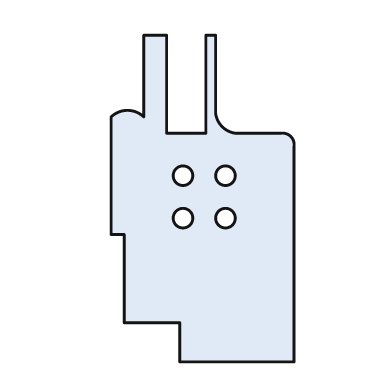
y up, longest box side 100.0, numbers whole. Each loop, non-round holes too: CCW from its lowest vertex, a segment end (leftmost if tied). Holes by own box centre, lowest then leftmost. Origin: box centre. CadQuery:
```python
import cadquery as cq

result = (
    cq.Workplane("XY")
    .moveTo(-7.0, -50.0)
    .lineTo(28.0, -50.0)
    .lineTo(28.0, 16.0)
    .threePointArc((27.0, 19.0), (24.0, 20.0))
    .lineTo(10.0, 20.0)
    .threePointArc((6.0, 22.0), (4.0, 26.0))
    .lineTo(4.0, 50.0)
    .lineTo(1.0, 50.0)
    .lineTo(1.0, 20.0)
    .lineTo(-11.0, 20.0)
    .lineTo(-11.0, 50.0)
    .lineTo(-18.0, 50.0)
    .lineTo(-18.0, 25.0)
    .threePointArc((-23.0, 27.0), (-28.0, 25.0))
    .lineTo(-28.0, -11.0)
    .lineTo(-24.0, -11.0)
    .lineTo(-24.0, -38.0)
    .lineTo(-7.0, -38.0)
    .close()
    .moveTo(-6.0, -6.0)
    .circle(3.0)
    .moveTo(7.0, -6.0)
    .circle(3.0)
    .moveTo(-6.0, 7.0)
    .circle(3.0)
    .moveTo(7.0, 7.0)
    .circle(3.0)
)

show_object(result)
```